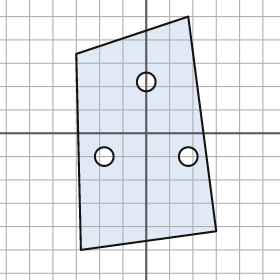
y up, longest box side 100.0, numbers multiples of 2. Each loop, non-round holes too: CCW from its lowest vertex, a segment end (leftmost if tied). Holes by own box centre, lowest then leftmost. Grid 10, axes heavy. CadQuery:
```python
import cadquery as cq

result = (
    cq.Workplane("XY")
    .moveTo(-28.0, -50.0)
    .lineTo(30.0, -42.0)
    .lineTo(18.0, 50.0)
    .lineTo(-30.0, 34.0)
    .close()
    .moveTo(-18.0, -10.0)
    .circle(4.0)
    .moveTo(18.0, -10.0)
    .circle(4.0)
    .moveTo(0.0, 22.0)
    .circle(4.0)
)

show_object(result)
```